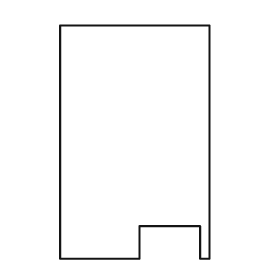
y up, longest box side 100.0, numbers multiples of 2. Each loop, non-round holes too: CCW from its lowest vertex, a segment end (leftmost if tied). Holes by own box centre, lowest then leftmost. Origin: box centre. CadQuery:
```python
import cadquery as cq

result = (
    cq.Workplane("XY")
    .moveTo(-32.0, -50.0)
    .lineTo(2.0, -50.0)
    .lineTo(2.0, -36.0)
    .lineTo(28.0, -36.0)
    .lineTo(28.0, -50.0)
    .lineTo(32.0, -50.0)
    .lineTo(32.0, 50.0)
    .lineTo(-32.0, 50.0)
    .close()
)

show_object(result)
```